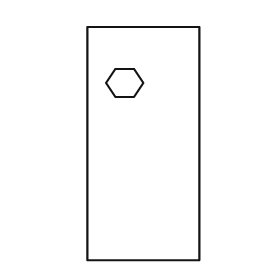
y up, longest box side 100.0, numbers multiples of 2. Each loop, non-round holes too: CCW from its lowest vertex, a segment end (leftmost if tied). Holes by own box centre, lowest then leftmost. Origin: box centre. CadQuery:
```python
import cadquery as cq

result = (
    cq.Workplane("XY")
    .moveTo(-24.0, -50.0)
    .lineTo(24.0, -50.0)
    .lineTo(24.0, 50.0)
    .lineTo(-24.0, 50.0)
    .close()
    .moveTo(-12.0, 20.0)
    .lineTo(-4.0, 20.0)
    .lineTo(0.0, 26.0)
    .lineTo(-4.0, 32.0)
    .lineTo(-12.0, 32.0)
    .lineTo(-16.0, 26.0)
    .close()
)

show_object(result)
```